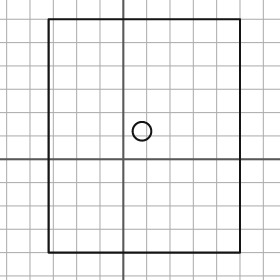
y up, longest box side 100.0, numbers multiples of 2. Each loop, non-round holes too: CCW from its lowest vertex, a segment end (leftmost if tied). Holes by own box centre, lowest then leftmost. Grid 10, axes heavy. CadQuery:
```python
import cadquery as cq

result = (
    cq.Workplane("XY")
    .moveTo(-32.0, -40.0)
    .lineTo(50.0, -40.0)
    .lineTo(50.0, 60.0)
    .lineTo(-32.0, 60.0)
    .close()
    .moveTo(8.0, 12.0)
    .circle(4.0)
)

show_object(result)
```